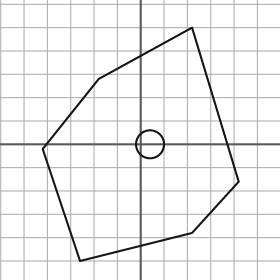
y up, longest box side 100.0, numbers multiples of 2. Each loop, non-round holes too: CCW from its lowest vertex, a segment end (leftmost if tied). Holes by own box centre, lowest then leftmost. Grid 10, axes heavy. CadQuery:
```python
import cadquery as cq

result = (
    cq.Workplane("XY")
    .moveTo(-26.0, -50.0)
    .lineTo(22.0, -38.0)
    .lineTo(42.0, -16.0)
    .lineTo(22.0, 50.0)
    .lineTo(-18.0, 28.0)
    .lineTo(-42.0, -2.0)
    .close()
    .moveTo(4.0, 0.0)
    .circle(6.0)
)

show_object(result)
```